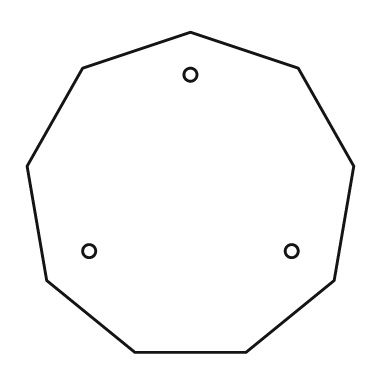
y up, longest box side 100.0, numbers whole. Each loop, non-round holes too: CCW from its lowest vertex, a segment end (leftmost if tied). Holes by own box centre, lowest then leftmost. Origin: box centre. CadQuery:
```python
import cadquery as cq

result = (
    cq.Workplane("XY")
    .moveTo(-17.0, -49.0)
    .lineTo(17.0, -49.0)
    .lineTo(44.0, -27.0)
    .lineTo(50.0, 8.0)
    .lineTo(33.0, 38.0)
    .lineTo(0.0, 49.0)
    .lineTo(-33.0, 38.0)
    .lineTo(-50.0, 8.0)
    .lineTo(-44.0, -27.0)
    .close()
    .moveTo(-31.0, -18.0)
    .circle(2.0)
    .moveTo(31.0, -18.0)
    .circle(2.0)
    .moveTo(0.0, 36.0)
    .circle(2.0)
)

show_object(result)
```